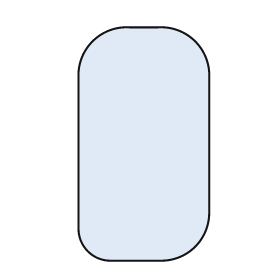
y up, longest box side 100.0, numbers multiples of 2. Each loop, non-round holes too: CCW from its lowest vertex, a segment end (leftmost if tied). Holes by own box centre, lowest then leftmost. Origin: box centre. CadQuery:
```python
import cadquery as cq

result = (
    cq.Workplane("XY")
    .moveTo(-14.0, -50.0)
    .lineTo(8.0, -50.0)
    .threePointArc((22.0, -44.0), (28.0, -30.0))
    .lineTo(28.0, 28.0)
    .threePointArc((22.0, 44.0), (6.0, 50.0))
    .lineTo(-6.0, 50.0)
    .threePointArc((-22.0, 44.0), (-28.0, 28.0))
    .lineTo(-28.0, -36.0)
    .threePointArc((-24.0, -46.0), (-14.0, -50.0))
    .close()
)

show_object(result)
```